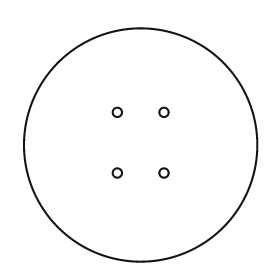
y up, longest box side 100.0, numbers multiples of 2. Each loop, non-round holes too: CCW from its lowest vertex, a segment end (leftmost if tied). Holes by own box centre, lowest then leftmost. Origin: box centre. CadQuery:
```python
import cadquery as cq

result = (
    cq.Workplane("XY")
    .moveTo(0.0, 0.0)
    .circle(50.0)
    .moveTo(-10.0, -12.0)
    .circle(2.0)
    .moveTo(10.0, -12.0)
    .circle(2.0)
    .moveTo(-10.0, 14.0)
    .circle(2.0)
    .moveTo(10.0, 14.0)
    .circle(2.0)
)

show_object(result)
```